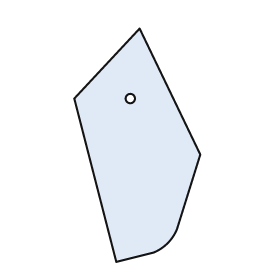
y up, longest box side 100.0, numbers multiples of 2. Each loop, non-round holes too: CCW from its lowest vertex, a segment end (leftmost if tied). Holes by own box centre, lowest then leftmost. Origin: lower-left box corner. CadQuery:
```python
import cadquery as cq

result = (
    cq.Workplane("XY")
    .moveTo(18.0, 0.0)
    .lineTo(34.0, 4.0)
    .threePointArc((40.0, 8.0), (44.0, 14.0))
    .lineTo(54.0, 46.0)
    .lineTo(28.0, 100.0)
    .lineTo(0.0, 70.0)
    .close()
    .moveTo(24.0, 70.0)
    .circle(2.0)
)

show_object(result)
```